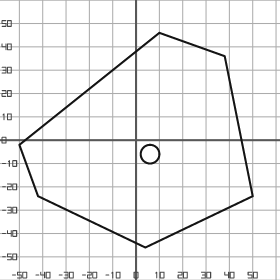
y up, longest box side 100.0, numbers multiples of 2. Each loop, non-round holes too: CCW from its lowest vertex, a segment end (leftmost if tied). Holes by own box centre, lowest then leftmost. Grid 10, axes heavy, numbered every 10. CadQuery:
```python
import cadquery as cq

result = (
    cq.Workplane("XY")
    .moveTo(4.0, -46.0)
    .lineTo(50.0, -24.0)
    .lineTo(38.0, 36.0)
    .lineTo(10.0, 46.0)
    .lineTo(-50.0, -2.0)
    .lineTo(-42.0, -24.0)
    .close()
    .moveTo(6.0, -6.0)
    .circle(4.0)
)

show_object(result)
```